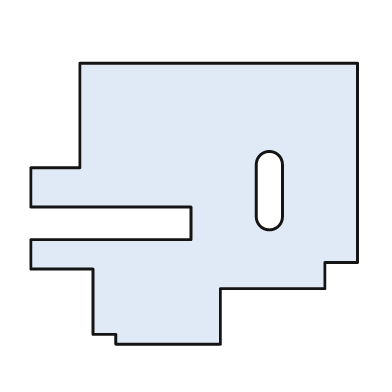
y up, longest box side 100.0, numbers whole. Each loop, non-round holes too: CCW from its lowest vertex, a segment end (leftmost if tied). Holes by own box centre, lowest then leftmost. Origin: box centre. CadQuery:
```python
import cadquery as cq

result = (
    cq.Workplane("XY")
    .moveTo(-24.0, -43.0)
    .lineTo(8.0, -43.0)
    .lineTo(8.0, -26.0)
    .lineTo(40.0, -26.0)
    .lineTo(40.0, -18.0)
    .lineTo(50.0, -18.0)
    .lineTo(50.0, 43.0)
    .lineTo(-35.0, 43.0)
    .lineTo(-35.0, 11.0)
    .lineTo(-50.0, 11.0)
    .lineTo(-50.0, -1.0)
    .lineTo(-1.0, -1.0)
    .lineTo(-1.0, -11.0)
    .lineTo(-50.0, -11.0)
    .lineTo(-50.0, -20.0)
    .lineTo(-31.0, -20.0)
    .lineTo(-31.0, -40.0)
    .lineTo(-24.0, -40.0)
    .close()
    .moveTo(19.0, -4.0)
    .threePointArc((23.0, -8.0), (27.0, -4.0))
    .lineTo(27.0, 12.0)
    .threePointArc((23.0, 16.0), (19.0, 12.0))
    .close()
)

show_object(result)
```